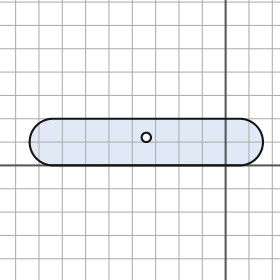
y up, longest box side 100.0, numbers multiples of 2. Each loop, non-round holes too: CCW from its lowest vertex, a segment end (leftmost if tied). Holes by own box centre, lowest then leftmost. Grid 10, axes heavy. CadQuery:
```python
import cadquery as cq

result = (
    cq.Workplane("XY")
    .moveTo(-74.0, 0.0)
    .lineTo(6.0, 0.0)
    .threePointArc((16.0, 10.0), (6.0, 20.0))
    .lineTo(-74.0, 20.0)
    .threePointArc((-84.0, 10.0), (-74.0, 0.0))
    .close()
    .moveTo(-34.0, 12.0)
    .circle(2.0)
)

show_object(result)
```